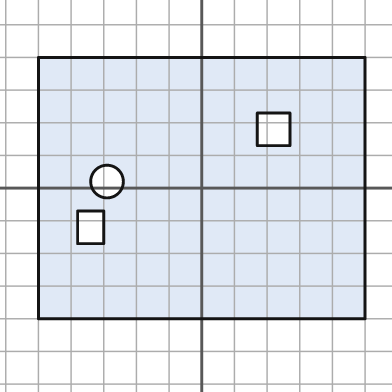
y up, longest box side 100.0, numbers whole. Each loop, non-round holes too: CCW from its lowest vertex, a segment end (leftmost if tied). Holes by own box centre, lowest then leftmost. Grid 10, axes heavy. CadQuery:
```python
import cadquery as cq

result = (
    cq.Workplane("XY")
    .moveTo(-50.0, -40.0)
    .lineTo(50.0, -40.0)
    .lineTo(50.0, 40.0)
    .lineTo(-50.0, 40.0)
    .close()
    .moveTo(-38.0, -17.0)
    .lineTo(-30.0, -17.0)
    .lineTo(-30.0, -7.0)
    .lineTo(-38.0, -7.0)
    .close()
    .moveTo(-29.0, 2.0)
    .circle(5.0)
    .moveTo(17.0, 13.0)
    .lineTo(27.0, 13.0)
    .lineTo(27.0, 23.0)
    .lineTo(17.0, 23.0)
    .close()
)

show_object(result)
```